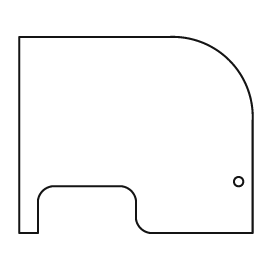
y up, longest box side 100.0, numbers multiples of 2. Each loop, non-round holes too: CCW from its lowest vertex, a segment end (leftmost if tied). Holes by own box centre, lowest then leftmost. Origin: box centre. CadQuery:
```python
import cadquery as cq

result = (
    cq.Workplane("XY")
    .moveTo(-50.0, -42.0)
    .lineTo(-42.0, -42.0)
    .lineTo(-42.0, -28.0)
    .threePointArc((-40.0, -24.0), (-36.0, -22.0))
    .lineTo(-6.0, -22.0)
    .threePointArc((-2.0, -24.0), (0.0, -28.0))
    .lineTo(0.0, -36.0)
    .threePointArc((2.0, -40.0), (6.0, -42.0))
    .lineTo(50.0, -42.0)
    .lineTo(50.0, 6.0)
    .threePointArc((40.0, 32.0), (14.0, 42.0))
    .lineTo(-50.0, 42.0)
    .close()
    .moveTo(44.0, -20.0)
    .circle(2.0)
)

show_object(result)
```